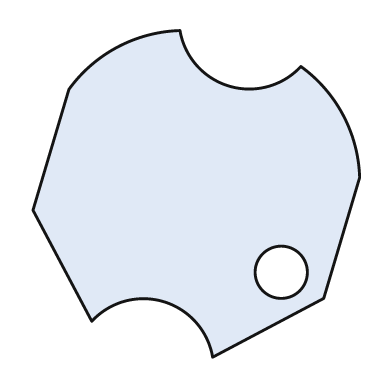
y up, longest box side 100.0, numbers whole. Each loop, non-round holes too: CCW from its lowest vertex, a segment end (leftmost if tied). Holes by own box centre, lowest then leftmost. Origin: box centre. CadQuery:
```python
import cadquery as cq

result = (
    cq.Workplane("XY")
    .moveTo(5.0, -50.0)
    .lineTo(39.0, -32.0)
    .lineTo(50.0, 5.0)
    .threePointArc((45.0, 24.0), (32.0, 39.0))
    .threePointArc((10.0, 33.0), (-5.0, 50.0))
    .threePointArc((-24.0, 45.0), (-39.0, 32.0))
    .lineTo(-50.0, -5.0)
    .lineTo(-32.0, -39.0)
    .threePointArc((-10.0, -33.0), (5.0, -50.0))
    .close()
    .moveTo(26.0, -24.0)
    .circle(8.0)
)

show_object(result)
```